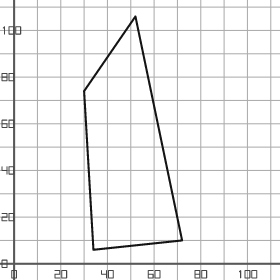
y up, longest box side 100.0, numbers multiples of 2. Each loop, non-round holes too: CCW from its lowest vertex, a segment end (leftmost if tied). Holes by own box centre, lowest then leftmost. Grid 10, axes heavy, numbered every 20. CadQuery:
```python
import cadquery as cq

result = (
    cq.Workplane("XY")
    .moveTo(34.0, 6.0)
    .lineTo(72.0, 10.0)
    .lineTo(52.0, 106.0)
    .lineTo(30.0, 74.0)
    .close()
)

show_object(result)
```